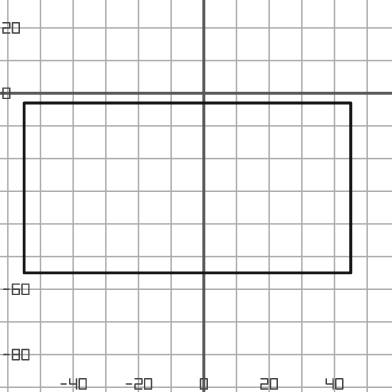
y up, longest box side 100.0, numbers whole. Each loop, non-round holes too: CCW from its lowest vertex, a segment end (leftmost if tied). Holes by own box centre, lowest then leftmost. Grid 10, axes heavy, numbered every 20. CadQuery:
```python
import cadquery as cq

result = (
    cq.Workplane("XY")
    .moveTo(-55.0, -55.0)
    .lineTo(45.0, -55.0)
    .lineTo(45.0, -3.0)
    .lineTo(-55.0, -3.0)
    .close()
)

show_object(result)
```